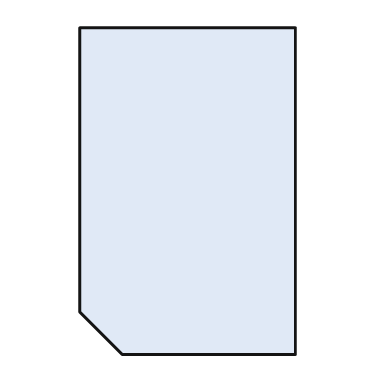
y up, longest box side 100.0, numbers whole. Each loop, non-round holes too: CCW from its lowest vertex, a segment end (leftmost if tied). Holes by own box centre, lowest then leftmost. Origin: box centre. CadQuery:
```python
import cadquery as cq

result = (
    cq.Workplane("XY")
    .moveTo(-20.0, -50.0)
    .lineTo(33.0, -50.0)
    .lineTo(33.0, 50.0)
    .lineTo(-33.0, 50.0)
    .lineTo(-33.0, -37.0)
    .close()
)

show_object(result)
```